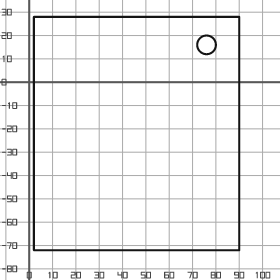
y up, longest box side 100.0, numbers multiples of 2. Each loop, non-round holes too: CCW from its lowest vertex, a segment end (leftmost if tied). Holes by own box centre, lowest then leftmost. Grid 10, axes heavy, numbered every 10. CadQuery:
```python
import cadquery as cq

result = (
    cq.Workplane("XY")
    .moveTo(2.0, -72.0)
    .lineTo(90.0, -72.0)
    .lineTo(90.0, 28.0)
    .lineTo(2.0, 28.0)
    .close()
    .moveTo(76.0, 16.0)
    .circle(4.0)
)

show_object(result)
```